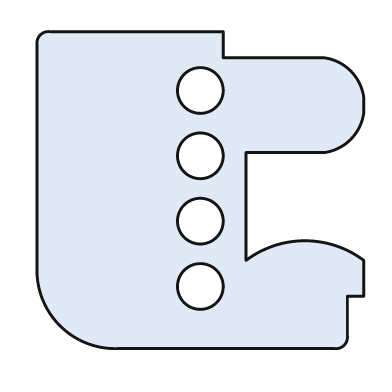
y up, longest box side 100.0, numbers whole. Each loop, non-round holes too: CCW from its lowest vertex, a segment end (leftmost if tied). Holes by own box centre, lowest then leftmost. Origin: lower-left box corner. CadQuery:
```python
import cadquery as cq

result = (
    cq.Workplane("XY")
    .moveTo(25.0, 0.0)
    .lineTo(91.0, 0.0)
    .threePointArc((94.0, 1.0), (95.0, 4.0))
    .lineTo(95.0, 16.0)
    .lineTo(100.0, 16.0)
    .lineTo(100.0, 27.0)
    .threePointArc((82.0, 33.0), (64.0, 27.0))
    .lineTo(64.0, 60.0)
    .lineTo(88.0, 60.0)
    .threePointArc((96.0, 64.0), (100.0, 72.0))
    .lineTo(100.0, 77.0)
    .threePointArc((96.0, 85.0), (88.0, 89.0))
    .lineTo(57.0, 89.0)
    .lineTo(57.0, 97.0)
    .lineTo(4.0, 97.0)
    .threePointArc((1.0, 96.0), (0.0, 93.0))
    .lineTo(0.0, 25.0)
    .threePointArc((7.0, 7.0), (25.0, 0.0))
    .close()
    .moveTo(50.0, 19.0)
    .circle(7.0)
    .moveTo(50.0, 39.0)
    .circle(7.0)
    .moveTo(50.0, 59.0)
    .circle(7.0)
    .moveTo(50.0, 79.0)
    .circle(7.0)
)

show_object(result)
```